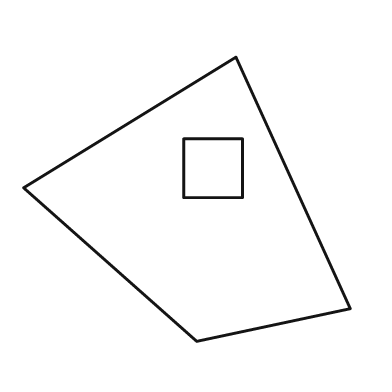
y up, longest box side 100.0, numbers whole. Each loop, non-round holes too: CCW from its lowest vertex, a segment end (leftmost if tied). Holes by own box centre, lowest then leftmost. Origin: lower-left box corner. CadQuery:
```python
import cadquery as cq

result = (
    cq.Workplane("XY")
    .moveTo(53.0, 0.0)
    .lineTo(100.0, 10.0)
    .lineTo(65.0, 87.0)
    .lineTo(0.0, 47.0)
    .close()
    .moveTo(49.0, 44.0)
    .lineTo(67.0, 44.0)
    .lineTo(67.0, 62.0)
    .lineTo(49.0, 62.0)
    .close()
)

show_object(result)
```